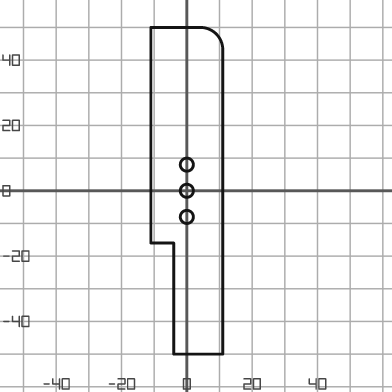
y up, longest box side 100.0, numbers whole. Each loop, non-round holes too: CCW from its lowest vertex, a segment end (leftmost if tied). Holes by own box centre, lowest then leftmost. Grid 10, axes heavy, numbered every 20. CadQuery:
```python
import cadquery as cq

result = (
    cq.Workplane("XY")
    .moveTo(-4.0, -50.0)
    .lineTo(11.0, -50.0)
    .lineTo(11.0, 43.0)
    .threePointArc((9.0, 48.0), (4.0, 50.0))
    .lineTo(-11.0, 50.0)
    .lineTo(-11.0, -16.0)
    .lineTo(-4.0, -16.0)
    .close()
    .moveTo(0.0, -8.0)
    .circle(2.0)
    .moveTo(0.0, 0.0)
    .circle(2.0)
    .moveTo(0.0, 8.0)
    .circle(2.0)
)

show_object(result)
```